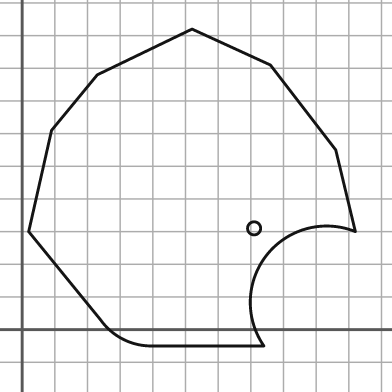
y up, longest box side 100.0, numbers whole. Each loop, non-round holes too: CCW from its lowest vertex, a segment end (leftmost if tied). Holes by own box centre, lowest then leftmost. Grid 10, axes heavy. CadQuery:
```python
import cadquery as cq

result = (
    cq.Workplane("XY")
    .moveTo(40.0, -5.0)
    .lineTo(74.0, -5.0)
    .threePointArc((75.0, 23.0), (102.0, 30.0))
    .lineTo(96.0, 55.0)
    .lineTo(76.0, 81.0)
    .lineTo(52.0, 92.0)
    .lineTo(23.0, 78.0)
    .lineTo(9.0, 61.0)
    .lineTo(2.0, 30.0)
    .lineTo(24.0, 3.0)
    .threePointArc((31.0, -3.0), (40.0, -5.0))
    .close()
    .moveTo(71.0, 31.0)
    .circle(2.0)
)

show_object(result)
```